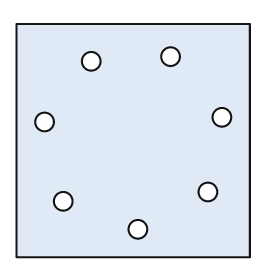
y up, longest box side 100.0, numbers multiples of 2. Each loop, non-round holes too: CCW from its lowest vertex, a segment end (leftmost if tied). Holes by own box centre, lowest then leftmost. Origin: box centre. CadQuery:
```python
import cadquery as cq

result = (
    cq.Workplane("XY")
    .moveTo(-50.0, -50.0)
    .lineTo(50.0, -50.0)
    .lineTo(50.0, 50.0)
    .lineTo(-50.0, 50.0)
    .close()
    .moveTo(2.0, -38.0)
    .circle(4.0)
    .moveTo(-30.0, -26.0)
    .circle(4.0)
    .moveTo(32.0, -22.0)
    .circle(4.0)
    .moveTo(-38.0, 8.0)
    .circle(4.0)
    .moveTo(38.0, 10.0)
    .circle(4.0)
    .moveTo(-18.0, 34.0)
    .circle(4.0)
    .moveTo(16.0, 36.0)
    .circle(4.0)
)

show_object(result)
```